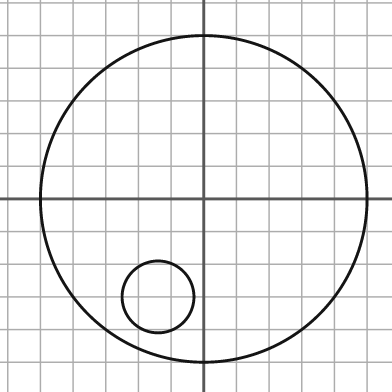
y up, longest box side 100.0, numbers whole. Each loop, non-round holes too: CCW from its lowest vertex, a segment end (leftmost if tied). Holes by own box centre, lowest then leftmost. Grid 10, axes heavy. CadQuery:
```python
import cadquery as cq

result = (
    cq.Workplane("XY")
    .moveTo(0.0, 0.0)
    .circle(50.0)
    .moveTo(-14.0, -30.0)
    .circle(11.0)
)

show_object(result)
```